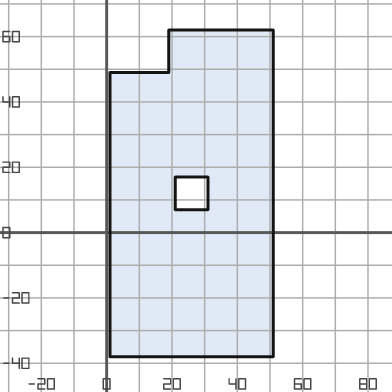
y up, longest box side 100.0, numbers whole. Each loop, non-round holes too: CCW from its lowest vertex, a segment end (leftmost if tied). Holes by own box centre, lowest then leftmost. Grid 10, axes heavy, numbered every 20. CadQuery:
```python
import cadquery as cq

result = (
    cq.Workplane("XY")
    .moveTo(1.0, -38.0)
    .lineTo(51.0, -38.0)
    .lineTo(51.0, 62.0)
    .lineTo(19.0, 62.0)
    .lineTo(19.0, 49.0)
    .lineTo(1.0, 49.0)
    .close()
    .moveTo(21.0, 7.0)
    .lineTo(31.0, 7.0)
    .lineTo(31.0, 17.0)
    .lineTo(21.0, 17.0)
    .close()
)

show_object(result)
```